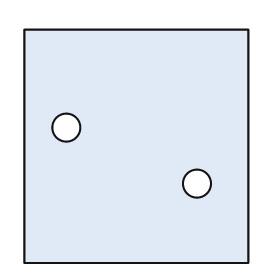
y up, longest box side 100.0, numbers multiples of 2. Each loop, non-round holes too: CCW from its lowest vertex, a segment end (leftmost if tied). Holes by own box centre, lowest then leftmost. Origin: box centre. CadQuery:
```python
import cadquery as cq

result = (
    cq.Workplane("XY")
    .moveTo(-48.0, -50.0)
    .lineTo(48.0, -50.0)
    .lineTo(48.0, 50.0)
    .lineTo(-48.0, 50.0)
    .close()
    .moveTo(26.0, -16.0)
    .circle(6.0)
    .moveTo(-30.0, 8.0)
    .circle(6.0)
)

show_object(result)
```